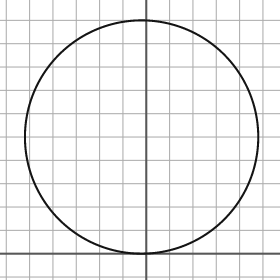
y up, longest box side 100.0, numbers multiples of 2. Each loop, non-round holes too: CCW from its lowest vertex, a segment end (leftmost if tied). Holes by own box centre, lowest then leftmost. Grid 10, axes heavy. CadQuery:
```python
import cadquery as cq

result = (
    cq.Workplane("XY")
    .moveTo(-2.0, 50.0)
    .circle(50.0)
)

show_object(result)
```